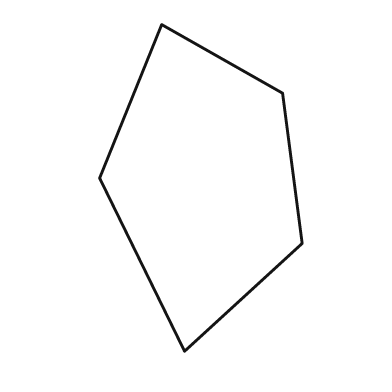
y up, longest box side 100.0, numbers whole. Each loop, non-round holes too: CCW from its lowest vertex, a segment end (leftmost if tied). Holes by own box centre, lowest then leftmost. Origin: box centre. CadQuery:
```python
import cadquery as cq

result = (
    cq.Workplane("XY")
    .moveTo(-5.0, -50.0)
    .lineTo(31.0, -17.0)
    .lineTo(25.0, 29.0)
    .lineTo(-12.0, 50.0)
    .lineTo(-31.0, 3.0)
    .close()
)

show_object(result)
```